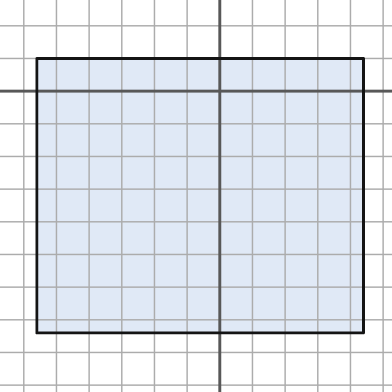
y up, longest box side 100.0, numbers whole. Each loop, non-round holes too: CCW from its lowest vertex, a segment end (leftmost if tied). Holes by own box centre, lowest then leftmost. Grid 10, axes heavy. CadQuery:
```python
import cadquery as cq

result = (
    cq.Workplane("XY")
    .moveTo(-56.0, -74.0)
    .lineTo(44.0, -74.0)
    .lineTo(44.0, 10.0)
    .lineTo(-56.0, 10.0)
    .close()
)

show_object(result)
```